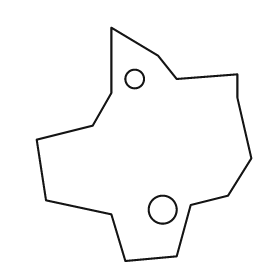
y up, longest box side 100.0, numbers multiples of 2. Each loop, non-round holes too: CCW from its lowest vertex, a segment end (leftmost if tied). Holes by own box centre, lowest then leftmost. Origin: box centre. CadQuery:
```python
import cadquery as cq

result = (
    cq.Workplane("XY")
    .moveTo(-8.0, -50.0)
    .lineTo(14.0, -48.0)
    .lineTo(20.0, -26.0)
    .lineTo(36.0, -22.0)
    .lineTo(46.0, -6.0)
    .lineTo(40.0, 20.0)
    .lineTo(40.0, 30.0)
    .lineTo(14.0, 28.0)
    .lineTo(6.0, 38.0)
    .lineTo(-14.0, 50.0)
    .lineTo(-14.0, 22.0)
    .lineTo(-22.0, 8.0)
    .lineTo(-46.0, 2.0)
    .lineTo(-42.0, -24.0)
    .lineTo(-14.0, -30.0)
    .close()
    .moveTo(8.0, -28.0)
    .circle(6.0)
    .moveTo(-4.0, 28.0)
    .circle(4.0)
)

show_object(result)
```